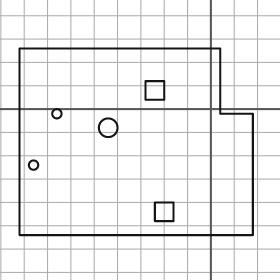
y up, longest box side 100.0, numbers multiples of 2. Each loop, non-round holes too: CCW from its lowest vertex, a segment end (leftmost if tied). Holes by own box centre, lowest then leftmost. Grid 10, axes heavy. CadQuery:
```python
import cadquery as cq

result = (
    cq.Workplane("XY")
    .moveTo(-82.0, -54.0)
    .lineTo(18.0, -54.0)
    .lineTo(18.0, -2.0)
    .lineTo(4.0, -2.0)
    .lineTo(4.0, 26.0)
    .lineTo(-82.0, 26.0)
    .close()
    .moveTo(-24.0, -48.0)
    .lineTo(-16.0, -48.0)
    .lineTo(-16.0, -40.0)
    .lineTo(-24.0, -40.0)
    .close()
    .moveTo(-76.0, -24.0)
    .circle(2.0)
    .moveTo(-44.0, -8.0)
    .circle(4.0)
    .moveTo(-66.0, -2.0)
    .circle(2.0)
    .moveTo(-28.0, 4.0)
    .lineTo(-20.0, 4.0)
    .lineTo(-20.0, 12.0)
    .lineTo(-28.0, 12.0)
    .close()
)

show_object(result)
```